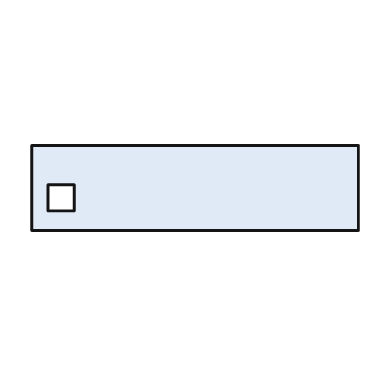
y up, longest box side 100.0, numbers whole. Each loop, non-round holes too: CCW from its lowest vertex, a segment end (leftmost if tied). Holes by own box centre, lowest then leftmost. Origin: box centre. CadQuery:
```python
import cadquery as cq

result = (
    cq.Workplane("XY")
    .moveTo(-50.0, -13.0)
    .lineTo(50.0, -13.0)
    .lineTo(50.0, 13.0)
    .lineTo(-50.0, 13.0)
    .close()
    .moveTo(-45.0, -7.0)
    .lineTo(-37.0, -7.0)
    .lineTo(-37.0, 1.0)
    .lineTo(-45.0, 1.0)
    .close()
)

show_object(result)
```